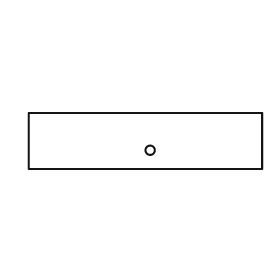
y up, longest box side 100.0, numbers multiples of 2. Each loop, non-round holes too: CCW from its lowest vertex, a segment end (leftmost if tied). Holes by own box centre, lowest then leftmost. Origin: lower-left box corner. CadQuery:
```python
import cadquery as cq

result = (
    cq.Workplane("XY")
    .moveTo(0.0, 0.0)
    .lineTo(100.0, 0.0)
    .lineTo(100.0, 24.0)
    .lineTo(0.0, 24.0)
    .close()
    .moveTo(52.0, 8.0)
    .circle(2.0)
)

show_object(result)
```